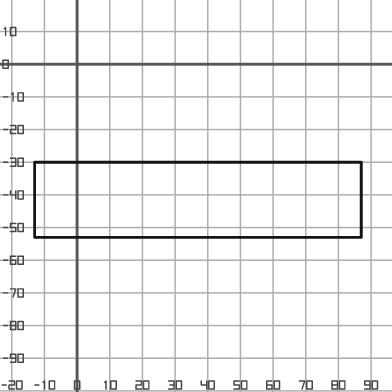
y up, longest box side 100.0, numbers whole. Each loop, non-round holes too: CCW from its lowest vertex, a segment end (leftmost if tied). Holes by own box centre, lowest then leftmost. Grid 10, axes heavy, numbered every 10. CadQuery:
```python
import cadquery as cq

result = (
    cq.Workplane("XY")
    .moveTo(-13.0, -53.0)
    .lineTo(87.0, -53.0)
    .lineTo(87.0, -30.0)
    .lineTo(-13.0, -30.0)
    .close()
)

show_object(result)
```